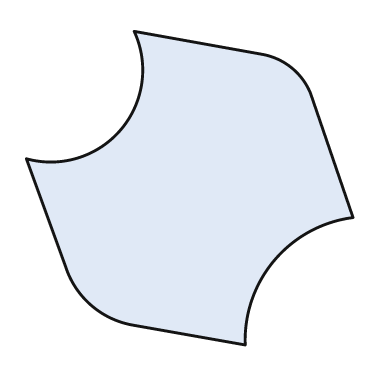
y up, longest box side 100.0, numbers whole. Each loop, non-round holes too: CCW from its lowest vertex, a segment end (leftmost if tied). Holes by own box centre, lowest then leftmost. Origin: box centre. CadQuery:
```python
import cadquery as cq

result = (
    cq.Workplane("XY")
    .moveTo(17.0, -48.0)
    .threePointArc((26.0, -22.0), (50.0, -9.0))
    .lineTo(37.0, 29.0)
    .threePointArc((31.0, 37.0), (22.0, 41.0))
    .lineTo(-17.0, 48.0)
    .threePointArc((-21.0, 18.0), (-50.0, 9.0))
    .lineTo(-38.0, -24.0)
    .threePointArc((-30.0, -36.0), (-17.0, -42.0))
    .close()
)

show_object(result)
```